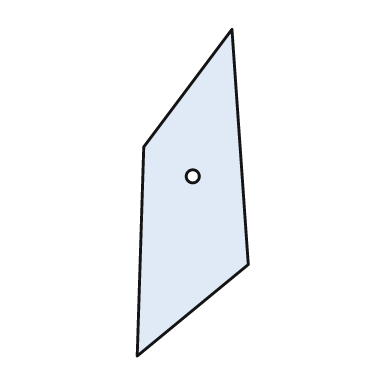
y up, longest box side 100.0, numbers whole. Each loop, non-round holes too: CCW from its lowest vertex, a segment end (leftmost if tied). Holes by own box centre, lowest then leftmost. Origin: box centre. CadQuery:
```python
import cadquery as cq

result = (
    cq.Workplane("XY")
    .moveTo(-17.0, -50.0)
    .lineTo(17.0, -22.0)
    .lineTo(12.0, 50.0)
    .lineTo(-15.0, 14.0)
    .close()
    .moveTo(0.0, 5.0)
    .circle(2.0)
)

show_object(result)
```